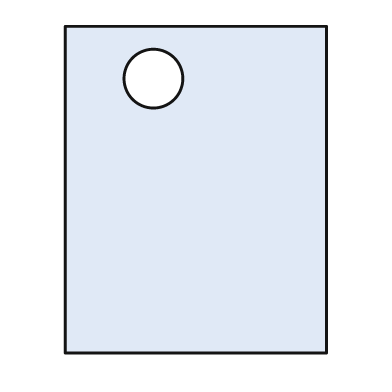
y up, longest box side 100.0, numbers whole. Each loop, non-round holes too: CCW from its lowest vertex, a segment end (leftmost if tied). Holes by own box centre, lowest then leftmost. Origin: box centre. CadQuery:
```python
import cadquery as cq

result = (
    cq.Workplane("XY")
    .moveTo(-40.0, -50.0)
    .lineTo(40.0, -50.0)
    .lineTo(40.0, 50.0)
    .lineTo(-40.0, 50.0)
    .close()
    .moveTo(-13.0, 34.0)
    .circle(9.0)
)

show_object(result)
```